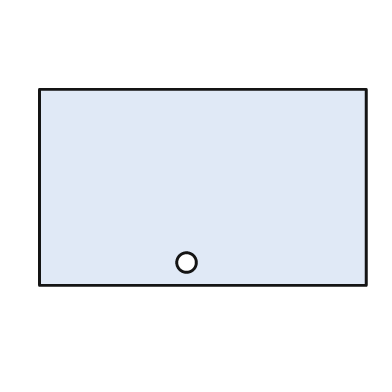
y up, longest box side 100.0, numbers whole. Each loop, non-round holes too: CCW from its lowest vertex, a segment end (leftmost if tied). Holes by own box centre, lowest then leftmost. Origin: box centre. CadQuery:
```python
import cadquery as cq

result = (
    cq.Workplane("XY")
    .moveTo(-50.0, -30.0)
    .lineTo(50.0, -30.0)
    .lineTo(50.0, 30.0)
    .lineTo(-50.0, 30.0)
    .close()
    .moveTo(-5.0, -23.0)
    .circle(3.0)
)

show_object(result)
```